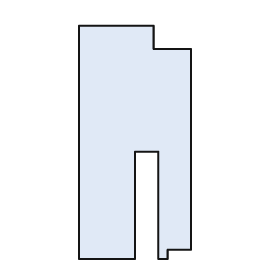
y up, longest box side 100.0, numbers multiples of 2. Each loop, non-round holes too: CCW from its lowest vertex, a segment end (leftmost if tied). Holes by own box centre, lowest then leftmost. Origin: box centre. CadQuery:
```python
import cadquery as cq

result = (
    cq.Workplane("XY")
    .moveTo(-24.0, -50.0)
    .lineTo(0.0, -50.0)
    .lineTo(0.0, -4.0)
    .lineTo(10.0, -4.0)
    .lineTo(10.0, -50.0)
    .lineTo(14.0, -50.0)
    .lineTo(14.0, -46.0)
    .lineTo(24.0, -46.0)
    .lineTo(24.0, 40.0)
    .lineTo(8.0, 40.0)
    .lineTo(8.0, 50.0)
    .lineTo(-24.0, 50.0)
    .close()
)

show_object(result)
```